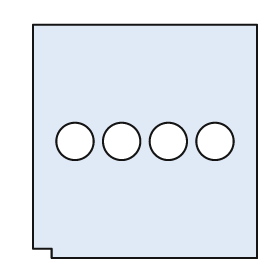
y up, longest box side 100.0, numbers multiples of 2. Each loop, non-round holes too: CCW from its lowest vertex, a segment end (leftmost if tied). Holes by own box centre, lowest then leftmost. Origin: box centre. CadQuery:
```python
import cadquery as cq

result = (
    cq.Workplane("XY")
    .moveTo(-40.0, -50.0)
    .lineTo(48.0, -50.0)
    .lineTo(48.0, 50.0)
    .lineTo(-48.0, 50.0)
    .lineTo(-48.0, -46.0)
    .lineTo(-40.0, -46.0)
    .close()
    .moveTo(-30.0, 0.0)
    .circle(8.0)
    .moveTo(-10.0, 0.0)
    .circle(8.0)
    .moveTo(10.0, 0.0)
    .circle(8.0)
    .moveTo(30.0, 0.0)
    .circle(8.0)
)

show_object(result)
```